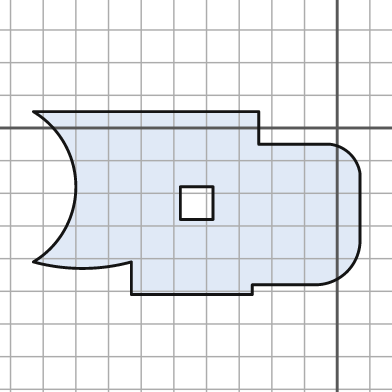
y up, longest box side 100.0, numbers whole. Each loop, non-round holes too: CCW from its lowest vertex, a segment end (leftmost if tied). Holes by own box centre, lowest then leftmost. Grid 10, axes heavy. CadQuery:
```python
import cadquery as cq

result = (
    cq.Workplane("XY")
    .moveTo(-63.0, -51.0)
    .lineTo(-26.0, -51.0)
    .lineTo(-26.0, -48.0)
    .lineTo(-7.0, -48.0)
    .threePointArc((3.0, -44.0), (7.0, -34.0))
    .lineTo(7.0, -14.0)
    .threePointArc((4.0, -8.0), (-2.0, -5.0))
    .lineTo(-24.0, -5.0)
    .lineTo(-24.0, 5.0)
    .lineTo(-93.0, 5.0)
    .threePointArc((-80.0, -18.0), (-93.0, -41.0))
    .threePointArc((-78.0, -43.0), (-63.0, -41.0))
    .close()
    .moveTo(-48.0, -28.0)
    .lineTo(-38.0, -28.0)
    .lineTo(-38.0, -18.0)
    .lineTo(-48.0, -18.0)
    .close()
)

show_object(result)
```